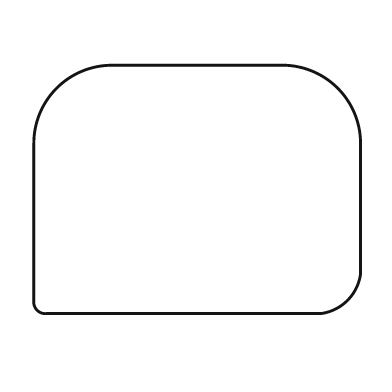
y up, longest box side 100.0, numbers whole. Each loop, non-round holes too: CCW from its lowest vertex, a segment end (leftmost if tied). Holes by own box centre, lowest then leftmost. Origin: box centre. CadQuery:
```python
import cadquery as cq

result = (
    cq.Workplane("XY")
    .moveTo(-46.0, -38.0)
    .lineTo(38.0, -38.0)
    .threePointArc((46.0, -34.0), (50.0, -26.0))
    .lineTo(50.0, 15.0)
    .threePointArc((43.0, 31.0), (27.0, 38.0))
    .lineTo(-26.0, 38.0)
    .threePointArc((-43.0, 31.0), (-50.0, 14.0))
    .lineTo(-50.0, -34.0)
    .threePointArc((-49.0, -37.0), (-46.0, -38.0))
    .close()
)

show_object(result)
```